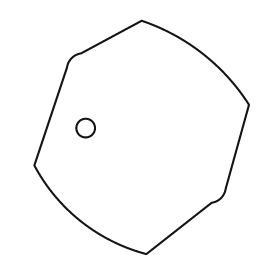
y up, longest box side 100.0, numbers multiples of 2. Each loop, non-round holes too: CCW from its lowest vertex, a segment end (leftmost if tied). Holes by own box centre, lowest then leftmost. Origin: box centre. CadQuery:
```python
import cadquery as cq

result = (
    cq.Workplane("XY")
    .moveTo(2.0, -50.0)
    .lineTo(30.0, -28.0)
    .threePointArc((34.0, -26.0), (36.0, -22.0))
    .lineTo(46.0, 14.0)
    .threePointArc((26.0, 36.0), (0.0, 50.0))
    .lineTo(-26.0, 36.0)
    .threePointArc((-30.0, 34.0), (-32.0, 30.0))
    .lineTo(-46.0, -12.0)
    .threePointArc((-26.0, -36.0), (2.0, -50.0))
    .close()
    .moveTo(-24.0, 4.0)
    .circle(4.0)
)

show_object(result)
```